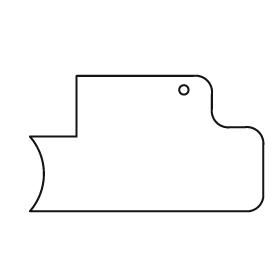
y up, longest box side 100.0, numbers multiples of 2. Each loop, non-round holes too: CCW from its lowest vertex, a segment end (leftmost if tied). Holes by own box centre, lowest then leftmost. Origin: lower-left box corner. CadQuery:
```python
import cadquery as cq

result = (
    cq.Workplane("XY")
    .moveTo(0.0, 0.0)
    .lineTo(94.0, 0.0)
    .threePointArc((98.0, 2.0), (100.0, 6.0))
    .lineTo(100.0, 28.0)
    .threePointArc((98.0, 34.0), (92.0, 36.0))
    .lineTo(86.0, 36.0)
    .threePointArc((80.0, 38.0), (78.0, 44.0))
    .lineTo(78.0, 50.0)
    .threePointArc((76.0, 56.0), (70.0, 58.0))
    .lineTo(20.0, 58.0)
    .lineTo(20.0, 32.0)
    .lineTo(0.0, 32.0)
    .threePointArc((6.0, 16.0), (0.0, 0.0))
    .close()
    .moveTo(66.0, 52.0)
    .circle(2.0)
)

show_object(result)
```